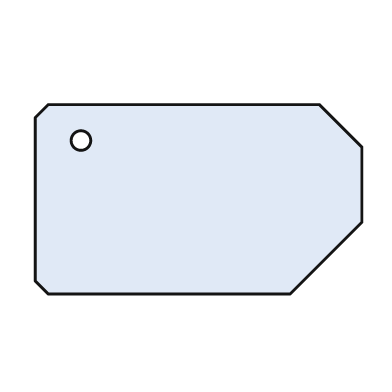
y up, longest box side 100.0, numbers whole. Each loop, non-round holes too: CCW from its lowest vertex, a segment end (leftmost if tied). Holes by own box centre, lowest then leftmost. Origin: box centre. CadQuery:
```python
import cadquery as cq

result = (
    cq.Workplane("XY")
    .moveTo(-46.0, -29.0)
    .lineTo(28.0, -29.0)
    .lineTo(50.0, -7.0)
    .lineTo(50.0, 16.0)
    .lineTo(37.0, 29.0)
    .lineTo(-46.0, 29.0)
    .lineTo(-50.0, 25.0)
    .lineTo(-50.0, -25.0)
    .close()
    .moveTo(-36.0, 18.0)
    .circle(3.0)
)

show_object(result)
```